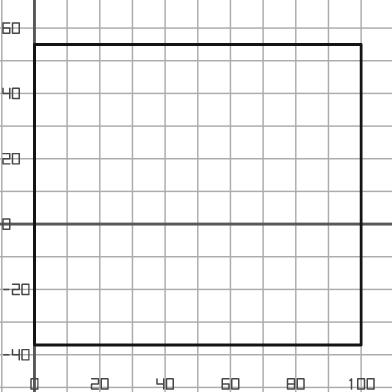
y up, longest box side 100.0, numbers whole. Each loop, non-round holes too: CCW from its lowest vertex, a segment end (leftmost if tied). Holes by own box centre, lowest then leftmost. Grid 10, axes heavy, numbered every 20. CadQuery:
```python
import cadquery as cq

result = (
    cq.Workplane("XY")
    .moveTo(0.0, -37.0)
    .lineTo(100.0, -37.0)
    .lineTo(100.0, 55.0)
    .lineTo(0.0, 55.0)
    .close()
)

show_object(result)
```